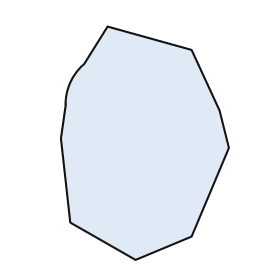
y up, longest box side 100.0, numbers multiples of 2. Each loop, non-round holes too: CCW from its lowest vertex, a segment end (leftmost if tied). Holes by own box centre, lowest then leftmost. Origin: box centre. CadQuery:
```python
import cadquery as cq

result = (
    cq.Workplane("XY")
    .moveTo(-4.0, -50.0)
    .lineTo(20.0, -40.0)
    .lineTo(36.0, -2.0)
    .lineTo(32.0, 14.0)
    .lineTo(20.0, 40.0)
    .lineTo(-16.0, 50.0)
    .lineTo(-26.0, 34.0)
    .threePointArc((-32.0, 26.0), (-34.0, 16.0))
    .lineTo(-36.0, 2.0)
    .lineTo(-32.0, -34.0)
    .close()
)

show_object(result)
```